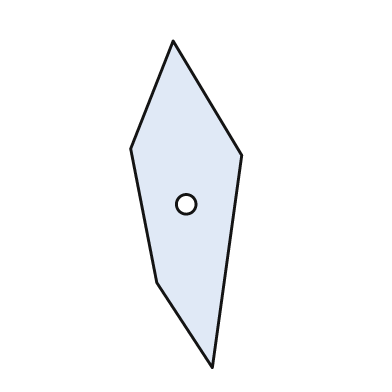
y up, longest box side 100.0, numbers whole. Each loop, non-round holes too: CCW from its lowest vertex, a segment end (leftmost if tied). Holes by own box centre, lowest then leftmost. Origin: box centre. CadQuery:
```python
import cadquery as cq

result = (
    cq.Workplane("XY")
    .moveTo(8.0, -50.0)
    .lineTo(17.0, 15.0)
    .lineTo(-4.0, 50.0)
    .lineTo(-17.0, 17.0)
    .lineTo(-9.0, -24.0)
    .close()
    .moveTo(0.0, 0.0)
    .circle(3.0)
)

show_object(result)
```